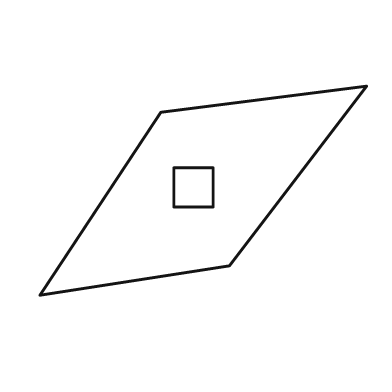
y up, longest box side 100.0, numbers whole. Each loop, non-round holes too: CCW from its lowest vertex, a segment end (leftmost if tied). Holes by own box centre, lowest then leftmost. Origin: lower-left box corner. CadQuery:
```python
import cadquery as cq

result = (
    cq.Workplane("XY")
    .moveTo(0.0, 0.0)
    .lineTo(58.0, 9.0)
    .lineTo(100.0, 64.0)
    .lineTo(37.0, 56.0)
    .close()
    .moveTo(41.0, 27.0)
    .lineTo(53.0, 27.0)
    .lineTo(53.0, 39.0)
    .lineTo(41.0, 39.0)
    .close()
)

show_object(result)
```